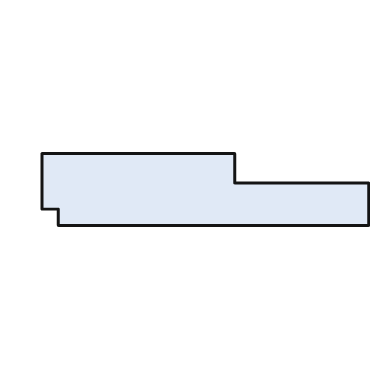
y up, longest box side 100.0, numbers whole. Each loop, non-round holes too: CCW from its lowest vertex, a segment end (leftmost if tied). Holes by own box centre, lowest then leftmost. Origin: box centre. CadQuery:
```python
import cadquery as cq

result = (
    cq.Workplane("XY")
    .moveTo(-45.0, -11.0)
    .lineTo(50.0, -11.0)
    .lineTo(50.0, 2.0)
    .lineTo(9.0, 2.0)
    .lineTo(9.0, 11.0)
    .lineTo(-50.0, 11.0)
    .lineTo(-50.0, -6.0)
    .lineTo(-45.0, -6.0)
    .close()
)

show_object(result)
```